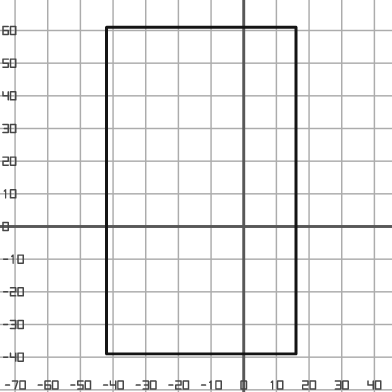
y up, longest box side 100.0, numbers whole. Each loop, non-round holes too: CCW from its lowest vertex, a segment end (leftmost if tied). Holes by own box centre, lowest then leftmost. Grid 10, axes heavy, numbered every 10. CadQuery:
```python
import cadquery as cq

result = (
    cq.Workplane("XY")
    .moveTo(-42.0, -39.0)
    .lineTo(16.0, -39.0)
    .lineTo(16.0, 61.0)
    .lineTo(-42.0, 61.0)
    .close()
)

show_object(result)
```